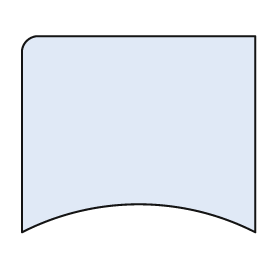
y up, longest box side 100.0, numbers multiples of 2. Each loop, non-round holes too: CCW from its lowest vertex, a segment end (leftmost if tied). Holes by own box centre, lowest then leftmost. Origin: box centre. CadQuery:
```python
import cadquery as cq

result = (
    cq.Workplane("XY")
    .moveTo(-50.0, -42.0)
    .threePointArc((0.0, -30.0), (50.0, -42.0))
    .lineTo(50.0, 42.0)
    .lineTo(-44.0, 42.0)
    .threePointArc((-48.0, 40.0), (-50.0, 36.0))
    .close()
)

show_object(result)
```